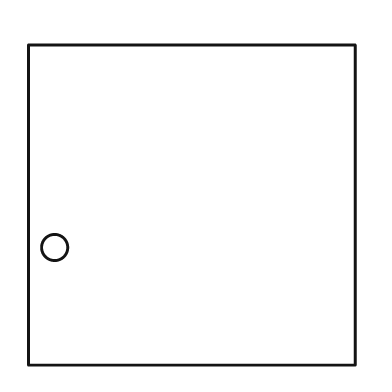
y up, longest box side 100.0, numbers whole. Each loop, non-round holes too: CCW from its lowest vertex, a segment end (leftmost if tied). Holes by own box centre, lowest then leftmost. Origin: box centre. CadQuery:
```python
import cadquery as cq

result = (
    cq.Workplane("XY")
    .moveTo(-50.0, -49.0)
    .lineTo(50.0, -49.0)
    .lineTo(50.0, 49.0)
    .lineTo(-50.0, 49.0)
    .close()
    .moveTo(-42.0, -13.0)
    .circle(4.0)
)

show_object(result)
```